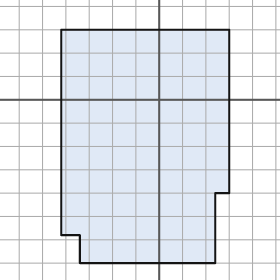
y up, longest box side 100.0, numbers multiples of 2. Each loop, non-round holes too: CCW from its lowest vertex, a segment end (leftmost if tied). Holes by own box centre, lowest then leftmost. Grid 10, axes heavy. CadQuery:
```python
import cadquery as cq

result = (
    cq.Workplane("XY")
    .moveTo(-34.0, -70.0)
    .lineTo(24.0, -70.0)
    .lineTo(24.0, -40.0)
    .lineTo(30.0, -40.0)
    .lineTo(30.0, 30.0)
    .lineTo(-42.0, 30.0)
    .lineTo(-42.0, -58.0)
    .lineTo(-34.0, -58.0)
    .close()
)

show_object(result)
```